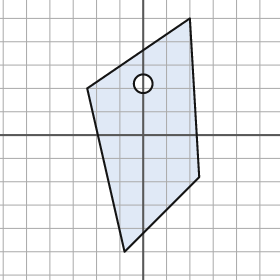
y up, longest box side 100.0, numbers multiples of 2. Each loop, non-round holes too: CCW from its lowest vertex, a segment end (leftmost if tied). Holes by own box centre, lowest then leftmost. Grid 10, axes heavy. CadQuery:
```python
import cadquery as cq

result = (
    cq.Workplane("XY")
    .moveTo(-8.0, -50.0)
    .lineTo(24.0, -18.0)
    .lineTo(20.0, 50.0)
    .lineTo(-24.0, 20.0)
    .close()
    .moveTo(0.0, 22.0)
    .circle(4.0)
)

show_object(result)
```